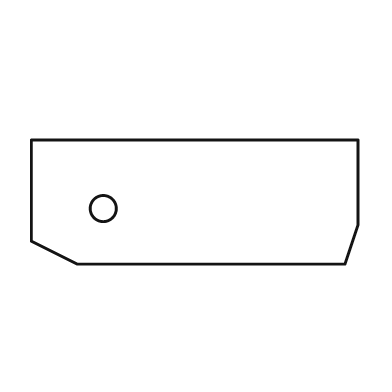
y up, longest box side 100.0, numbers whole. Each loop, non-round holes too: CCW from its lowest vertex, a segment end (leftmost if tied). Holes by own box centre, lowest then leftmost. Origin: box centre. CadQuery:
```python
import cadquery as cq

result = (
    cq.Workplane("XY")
    .moveTo(-36.0, -19.0)
    .lineTo(46.0, -19.0)
    .lineTo(50.0, -7.0)
    .lineTo(50.0, 19.0)
    .lineTo(-50.0, 19.0)
    .lineTo(-50.0, -12.0)
    .close()
    .moveTo(-28.0, -2.0)
    .circle(4.0)
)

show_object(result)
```